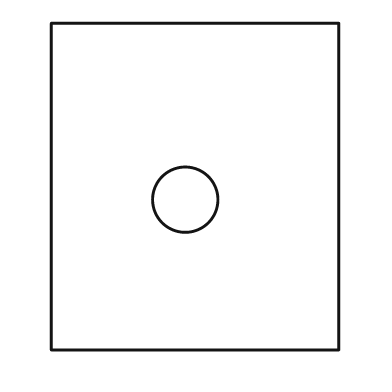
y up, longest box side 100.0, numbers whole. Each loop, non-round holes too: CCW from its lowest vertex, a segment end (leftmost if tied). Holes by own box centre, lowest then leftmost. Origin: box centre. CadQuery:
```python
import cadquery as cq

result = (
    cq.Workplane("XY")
    .moveTo(-44.0, -50.0)
    .lineTo(44.0, -50.0)
    .lineTo(44.0, 50.0)
    .lineTo(-44.0, 50.0)
    .close()
    .moveTo(-3.0, -4.0)
    .circle(10.0)
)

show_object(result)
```